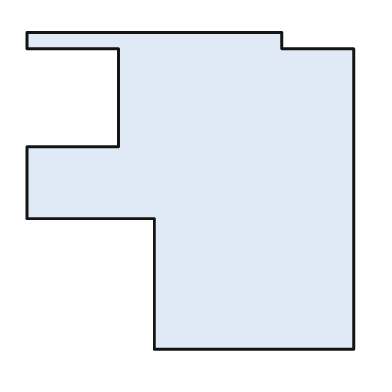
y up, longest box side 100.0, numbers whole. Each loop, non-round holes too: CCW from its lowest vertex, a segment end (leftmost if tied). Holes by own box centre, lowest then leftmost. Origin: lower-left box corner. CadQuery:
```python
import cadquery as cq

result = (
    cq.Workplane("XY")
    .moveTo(39.0, 0.0)
    .lineTo(100.0, 0.0)
    .lineTo(100.0, 92.0)
    .lineTo(78.0, 92.0)
    .lineTo(78.0, 97.0)
    .lineTo(0.0, 97.0)
    .lineTo(0.0, 92.0)
    .lineTo(28.0, 92.0)
    .lineTo(28.0, 62.0)
    .lineTo(0.0, 62.0)
    .lineTo(0.0, 40.0)
    .lineTo(39.0, 40.0)
    .close()
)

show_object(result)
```